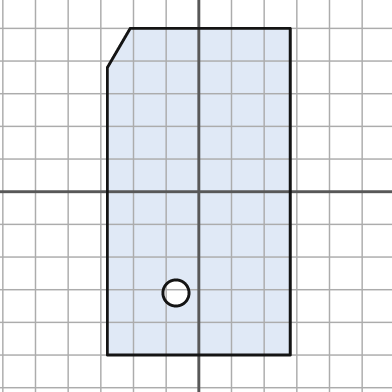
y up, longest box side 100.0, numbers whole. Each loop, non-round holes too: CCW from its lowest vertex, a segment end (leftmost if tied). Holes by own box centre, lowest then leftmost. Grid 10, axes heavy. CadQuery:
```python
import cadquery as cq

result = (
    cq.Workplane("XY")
    .moveTo(-28.0, -50.0)
    .lineTo(28.0, -50.0)
    .lineTo(28.0, 50.0)
    .lineTo(-21.0, 50.0)
    .lineTo(-28.0, 38.0)
    .close()
    .moveTo(-7.0, -31.0)
    .circle(4.0)
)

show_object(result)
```